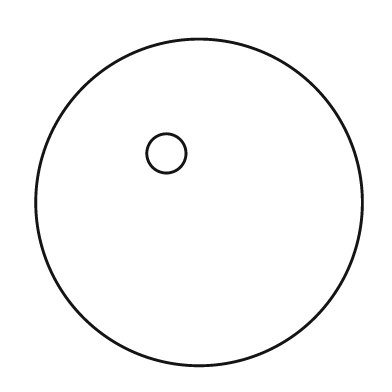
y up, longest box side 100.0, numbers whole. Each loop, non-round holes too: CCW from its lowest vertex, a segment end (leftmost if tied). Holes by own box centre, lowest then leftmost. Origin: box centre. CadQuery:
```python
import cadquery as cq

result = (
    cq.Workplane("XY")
    .moveTo(0.0, 0.0)
    .circle(50.0)
    .moveTo(-10.0, 15.0)
    .circle(6.0)
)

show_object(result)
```